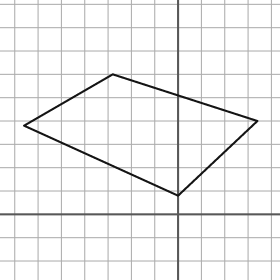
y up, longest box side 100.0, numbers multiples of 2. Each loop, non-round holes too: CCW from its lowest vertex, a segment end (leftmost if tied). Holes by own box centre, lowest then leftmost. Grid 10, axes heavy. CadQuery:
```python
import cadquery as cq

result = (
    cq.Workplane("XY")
    .moveTo(0.0, 8.0)
    .lineTo(34.0, 40.0)
    .lineTo(-28.0, 60.0)
    .lineTo(-66.0, 38.0)
    .close()
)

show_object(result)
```